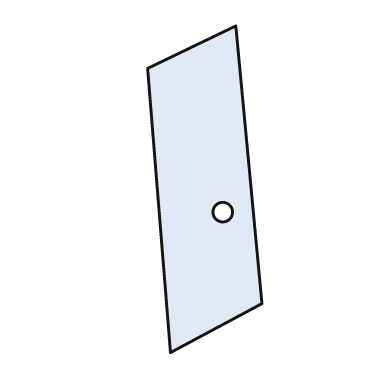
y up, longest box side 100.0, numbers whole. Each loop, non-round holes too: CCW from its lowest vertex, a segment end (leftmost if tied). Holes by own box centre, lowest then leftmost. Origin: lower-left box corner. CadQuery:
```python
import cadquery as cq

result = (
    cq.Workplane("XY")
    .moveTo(7.0, 0.0)
    .lineTo(35.0, 15.0)
    .lineTo(27.0, 100.0)
    .lineTo(0.0, 87.0)
    .close()
    .moveTo(23.0, 43.0)
    .circle(3.0)
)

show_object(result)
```